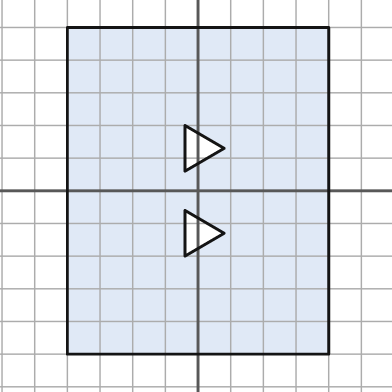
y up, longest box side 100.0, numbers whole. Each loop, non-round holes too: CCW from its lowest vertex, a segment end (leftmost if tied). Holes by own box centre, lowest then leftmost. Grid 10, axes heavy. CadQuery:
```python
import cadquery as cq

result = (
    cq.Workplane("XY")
    .moveTo(-40.0, -50.0)
    .lineTo(40.0, -50.0)
    .lineTo(40.0, 50.0)
    .lineTo(-40.0, 50.0)
    .close()
    .moveTo(-4.0, -20.0)
    .lineTo(8.0, -13.0)
    .lineTo(-4.0, -6.0)
    .close()
    .moveTo(-4.0, 6.0)
    .lineTo(8.0, 13.0)
    .lineTo(-4.0, 20.0)
    .close()
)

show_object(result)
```